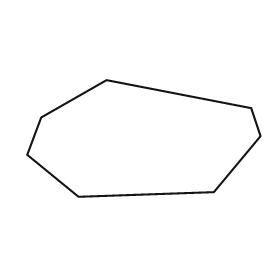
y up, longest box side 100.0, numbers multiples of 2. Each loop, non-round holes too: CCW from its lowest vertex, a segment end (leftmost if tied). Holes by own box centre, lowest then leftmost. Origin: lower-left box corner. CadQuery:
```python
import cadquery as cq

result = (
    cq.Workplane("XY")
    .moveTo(22.0, 0.0)
    .lineTo(80.0, 2.0)
    .lineTo(100.0, 26.0)
    .lineTo(96.0, 38.0)
    .lineTo(34.0, 50.0)
    .lineTo(6.0, 34.0)
    .lineTo(0.0, 18.0)
    .close()
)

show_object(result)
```